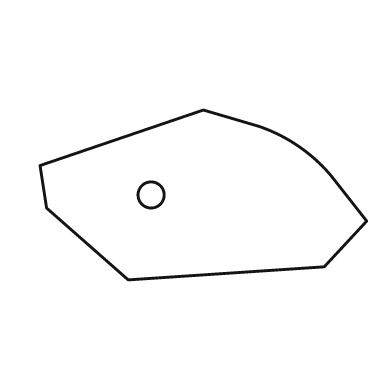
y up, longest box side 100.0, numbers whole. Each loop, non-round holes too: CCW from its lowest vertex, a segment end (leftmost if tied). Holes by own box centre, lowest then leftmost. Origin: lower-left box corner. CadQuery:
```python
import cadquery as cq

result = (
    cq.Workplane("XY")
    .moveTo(27.0, 0.0)
    .lineTo(87.0, 4.0)
    .lineTo(100.0, 18.0)
    .lineTo(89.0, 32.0)
    .threePointArc((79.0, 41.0), (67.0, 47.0))
    .lineTo(50.0, 52.0)
    .lineTo(0.0, 35.0)
    .lineTo(2.0, 22.0)
    .close()
    .moveTo(34.0, 26.0)
    .circle(4.0)
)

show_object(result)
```